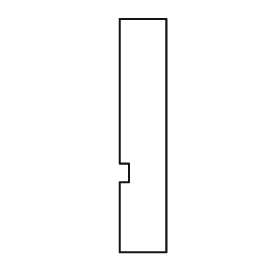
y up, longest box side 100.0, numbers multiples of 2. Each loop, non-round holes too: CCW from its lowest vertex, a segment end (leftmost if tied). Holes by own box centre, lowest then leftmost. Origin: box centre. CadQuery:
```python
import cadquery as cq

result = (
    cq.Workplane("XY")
    .moveTo(-10.0, -50.0)
    .lineTo(10.0, -50.0)
    .lineTo(10.0, 50.0)
    .lineTo(-10.0, 50.0)
    .lineTo(-10.0, -12.0)
    .lineTo(-6.0, -12.0)
    .lineTo(-6.0, -20.0)
    .lineTo(-10.0, -20.0)
    .close()
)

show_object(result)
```